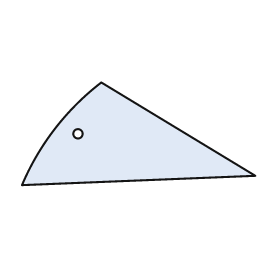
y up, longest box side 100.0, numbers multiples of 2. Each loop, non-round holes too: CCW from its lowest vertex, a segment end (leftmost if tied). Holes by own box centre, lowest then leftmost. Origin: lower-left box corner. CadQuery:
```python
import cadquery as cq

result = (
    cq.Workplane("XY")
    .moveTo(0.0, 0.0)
    .lineTo(100.0, 4.0)
    .lineTo(34.0, 44.0)
    .threePointArc((14.0, 24.0), (0.0, 0.0))
    .close()
    .moveTo(24.0, 22.0)
    .circle(2.0)
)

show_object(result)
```